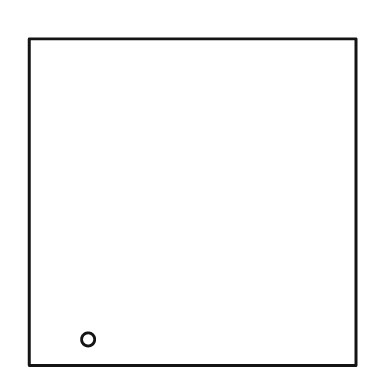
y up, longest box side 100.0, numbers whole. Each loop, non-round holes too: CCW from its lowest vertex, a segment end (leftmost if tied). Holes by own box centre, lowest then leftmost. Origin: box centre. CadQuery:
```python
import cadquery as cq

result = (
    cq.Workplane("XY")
    .moveTo(-50.0, -50.0)
    .lineTo(50.0, -50.0)
    .lineTo(50.0, 50.0)
    .lineTo(-50.0, 50.0)
    .close()
    .moveTo(-32.0, -42.0)
    .circle(2.0)
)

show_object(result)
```